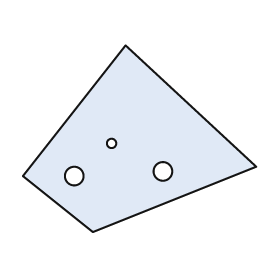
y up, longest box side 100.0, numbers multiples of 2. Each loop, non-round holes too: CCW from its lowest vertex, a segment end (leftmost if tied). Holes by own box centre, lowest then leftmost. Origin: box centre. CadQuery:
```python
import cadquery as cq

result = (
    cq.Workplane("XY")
    .moveTo(-20.0, -40.0)
    .lineTo(50.0, -12.0)
    .lineTo(-6.0, 40.0)
    .lineTo(-50.0, -16.0)
    .close()
    .moveTo(-28.0, -16.0)
    .circle(4.0)
    .moveTo(10.0, -14.0)
    .circle(4.0)
    .moveTo(-12.0, -2.0)
    .circle(2.0)
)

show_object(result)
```